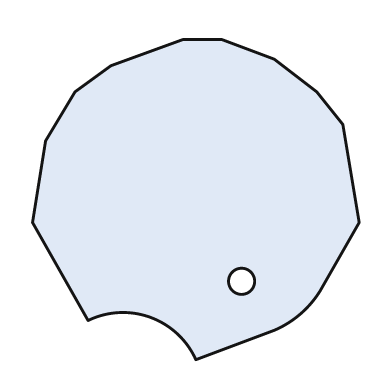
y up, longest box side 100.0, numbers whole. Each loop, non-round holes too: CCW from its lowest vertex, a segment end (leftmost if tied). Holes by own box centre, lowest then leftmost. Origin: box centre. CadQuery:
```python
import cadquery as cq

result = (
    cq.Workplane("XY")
    .moveTo(0.0, -49.0)
    .lineTo(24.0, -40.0)
    .threePointArc((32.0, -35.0), (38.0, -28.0))
    .lineTo(50.0, -7.0)
    .lineTo(45.0, 23.0)
    .lineTo(37.0, 33.0)
    .lineTo(24.0, 43.0)
    .lineTo(8.0, 49.0)
    .lineTo(-4.0, 49.0)
    .lineTo(-26.0, 41.0)
    .lineTo(-37.0, 33.0)
    .lineTo(-46.0, 18.0)
    .lineTo(-50.0, -7.0)
    .lineTo(-33.0, -37.0)
    .threePointArc((-14.0, -36.0), (0.0, -49.0))
    .close()
    .moveTo(14.0, -25.0)
    .circle(4.0)
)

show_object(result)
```